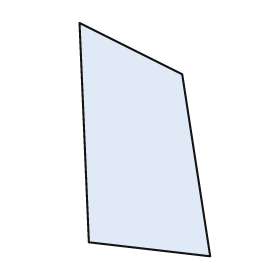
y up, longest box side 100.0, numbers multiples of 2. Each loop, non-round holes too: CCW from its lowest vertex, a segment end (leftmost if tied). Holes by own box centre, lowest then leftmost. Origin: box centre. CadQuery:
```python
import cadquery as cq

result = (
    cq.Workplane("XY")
    .moveTo(28.0, -50.0)
    .lineTo(16.0, 28.0)
    .lineTo(-28.0, 50.0)
    .lineTo(-24.0, -44.0)
    .close()
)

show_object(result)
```